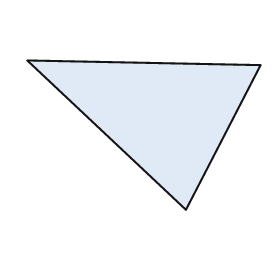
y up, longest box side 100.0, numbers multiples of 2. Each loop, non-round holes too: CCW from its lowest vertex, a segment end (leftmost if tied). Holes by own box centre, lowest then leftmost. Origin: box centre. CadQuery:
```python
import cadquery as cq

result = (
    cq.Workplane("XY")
    .moveTo(18.0, -32.0)
    .lineTo(50.0, 30.0)
    .lineTo(-50.0, 32.0)
    .close()
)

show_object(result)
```